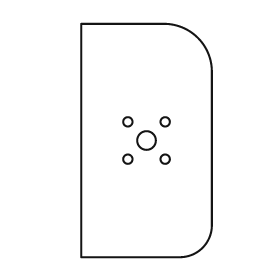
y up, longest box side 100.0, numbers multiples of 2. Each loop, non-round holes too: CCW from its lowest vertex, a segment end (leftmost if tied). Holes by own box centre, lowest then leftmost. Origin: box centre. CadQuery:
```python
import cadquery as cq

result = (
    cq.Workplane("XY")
    .moveTo(-28.0, -50.0)
    .lineTo(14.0, -50.0)
    .threePointArc((24.0, -46.0), (28.0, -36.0))
    .lineTo(28.0, 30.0)
    .threePointArc((22.0, 44.0), (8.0, 50.0))
    .lineTo(-28.0, 50.0)
    .close()
    .moveTo(-8.0, -8.0)
    .circle(2.0)
    .moveTo(8.0, -8.0)
    .circle(2.0)
    .moveTo(0.0, 0.0)
    .circle(4.0)
    .moveTo(-8.0, 8.0)
    .circle(2.0)
    .moveTo(8.0, 8.0)
    .circle(2.0)
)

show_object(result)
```